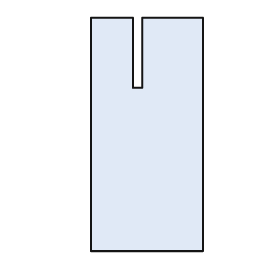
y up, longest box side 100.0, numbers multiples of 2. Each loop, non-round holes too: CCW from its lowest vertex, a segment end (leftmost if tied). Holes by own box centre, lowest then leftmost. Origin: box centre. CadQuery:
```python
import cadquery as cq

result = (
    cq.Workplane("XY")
    .moveTo(-24.0, -50.0)
    .lineTo(24.0, -50.0)
    .lineTo(24.0, 50.0)
    .lineTo(-2.0, 50.0)
    .lineTo(-2.0, 20.0)
    .lineTo(-6.0, 20.0)
    .lineTo(-6.0, 50.0)
    .lineTo(-24.0, 50.0)
    .close()
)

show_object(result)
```